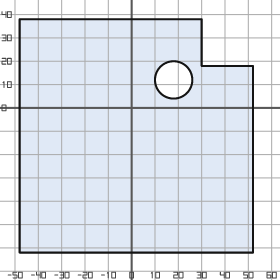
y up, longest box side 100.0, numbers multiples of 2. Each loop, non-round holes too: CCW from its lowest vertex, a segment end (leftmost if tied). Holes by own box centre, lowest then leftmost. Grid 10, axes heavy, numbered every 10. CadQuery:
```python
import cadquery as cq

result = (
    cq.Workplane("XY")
    .moveTo(-48.0, -62.0)
    .lineTo(52.0, -62.0)
    .lineTo(52.0, 18.0)
    .lineTo(30.0, 18.0)
    .lineTo(30.0, 38.0)
    .lineTo(-48.0, 38.0)
    .close()
    .moveTo(18.0, 12.0)
    .circle(8.0)
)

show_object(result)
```